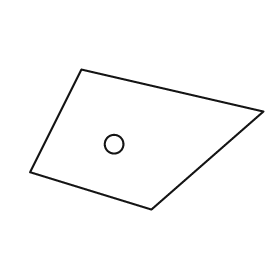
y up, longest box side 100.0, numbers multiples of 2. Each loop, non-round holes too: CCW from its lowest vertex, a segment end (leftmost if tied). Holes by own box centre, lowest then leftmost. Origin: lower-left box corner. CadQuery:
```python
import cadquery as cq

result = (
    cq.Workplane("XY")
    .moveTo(52.0, 0.0)
    .lineTo(100.0, 42.0)
    .lineTo(22.0, 60.0)
    .lineTo(0.0, 16.0)
    .close()
    .moveTo(36.0, 28.0)
    .circle(4.0)
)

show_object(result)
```